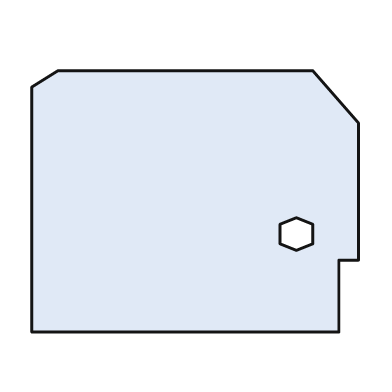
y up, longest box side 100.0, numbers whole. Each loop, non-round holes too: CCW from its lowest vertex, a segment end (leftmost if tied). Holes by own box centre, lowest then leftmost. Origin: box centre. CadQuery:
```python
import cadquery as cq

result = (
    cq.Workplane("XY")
    .moveTo(-50.0, -40.0)
    .lineTo(44.0, -40.0)
    .lineTo(44.0, -18.0)
    .lineTo(50.0, -18.0)
    .lineTo(50.0, 24.0)
    .lineTo(36.0, 40.0)
    .lineTo(-42.0, 40.0)
    .lineTo(-50.0, 35.0)
    .close()
    .moveTo(31.0, -15.0)
    .lineTo(36.0, -13.0)
    .lineTo(36.0, -7.0)
    .lineTo(31.0, -5.0)
    .lineTo(26.0, -7.0)
    .lineTo(26.0, -13.0)
    .close()
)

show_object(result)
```